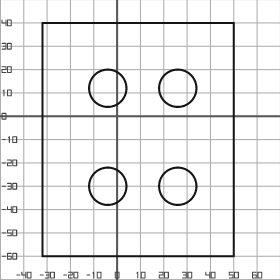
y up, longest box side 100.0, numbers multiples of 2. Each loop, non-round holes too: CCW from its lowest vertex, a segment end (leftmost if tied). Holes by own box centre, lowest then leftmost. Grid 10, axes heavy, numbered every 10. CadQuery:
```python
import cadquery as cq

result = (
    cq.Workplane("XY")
    .moveTo(-32.0, -60.0)
    .lineTo(50.0, -60.0)
    .lineTo(50.0, 40.0)
    .lineTo(-32.0, 40.0)
    .close()
    .moveTo(-4.0, -30.0)
    .circle(8.0)
    .moveTo(26.0, -30.0)
    .circle(8.0)
    .moveTo(-4.0, 12.0)
    .circle(8.0)
    .moveTo(26.0, 12.0)
    .circle(8.0)
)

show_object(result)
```